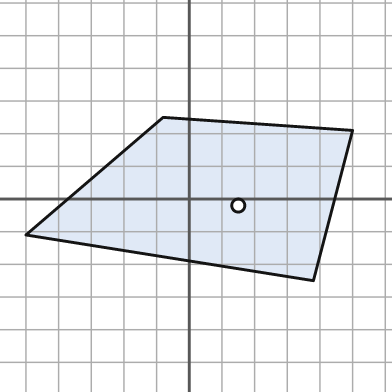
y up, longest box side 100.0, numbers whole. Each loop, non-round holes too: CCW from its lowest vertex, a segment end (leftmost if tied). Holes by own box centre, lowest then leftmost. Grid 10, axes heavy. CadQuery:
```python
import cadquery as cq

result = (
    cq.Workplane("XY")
    .moveTo(38.0, -25.0)
    .lineTo(50.0, 21.0)
    .lineTo(-8.0, 25.0)
    .lineTo(-50.0, -11.0)
    .close()
    .moveTo(15.0, -2.0)
    .circle(2.0)
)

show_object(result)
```